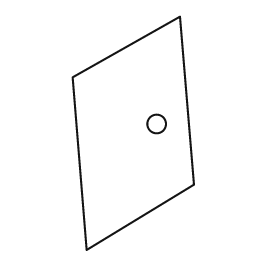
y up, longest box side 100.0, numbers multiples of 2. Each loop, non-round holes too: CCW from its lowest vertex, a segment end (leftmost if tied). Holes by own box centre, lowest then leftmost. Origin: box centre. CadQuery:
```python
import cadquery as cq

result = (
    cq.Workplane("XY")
    .moveTo(-20.0, -50.0)
    .lineTo(26.0, -22.0)
    .lineTo(20.0, 50.0)
    .lineTo(-26.0, 24.0)
    .close()
    .moveTo(10.0, 4.0)
    .circle(4.0)
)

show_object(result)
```